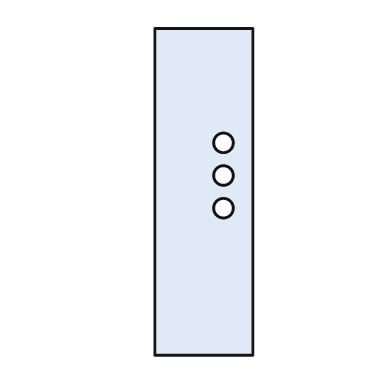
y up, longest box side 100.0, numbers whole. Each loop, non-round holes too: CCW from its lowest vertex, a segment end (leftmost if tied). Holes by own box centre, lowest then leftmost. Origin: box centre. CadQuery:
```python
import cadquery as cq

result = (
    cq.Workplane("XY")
    .moveTo(-15.0, -50.0)
    .lineTo(15.0, -50.0)
    .lineTo(15.0, 50.0)
    .lineTo(-15.0, 50.0)
    .close()
    .moveTo(6.0, -5.0)
    .circle(3.0)
    .moveTo(6.0, 5.0)
    .circle(3.0)
    .moveTo(6.0, 15.0)
    .circle(3.0)
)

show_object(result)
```